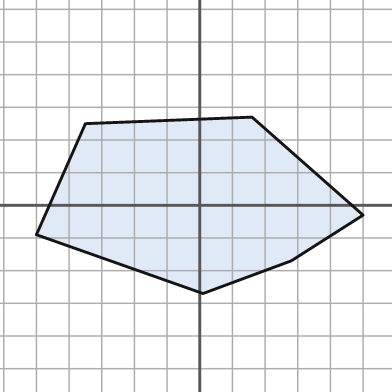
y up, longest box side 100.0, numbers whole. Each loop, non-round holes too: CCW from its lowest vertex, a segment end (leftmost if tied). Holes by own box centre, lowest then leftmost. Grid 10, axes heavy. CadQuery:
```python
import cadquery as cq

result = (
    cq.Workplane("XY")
    .moveTo(1.0, -27.0)
    .lineTo(28.0, -17.0)
    .lineTo(50.0, -3.0)
    .lineTo(16.0, 27.0)
    .lineTo(-35.0, 25.0)
    .lineTo(-50.0, -9.0)
    .close()
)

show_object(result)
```